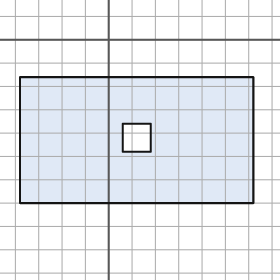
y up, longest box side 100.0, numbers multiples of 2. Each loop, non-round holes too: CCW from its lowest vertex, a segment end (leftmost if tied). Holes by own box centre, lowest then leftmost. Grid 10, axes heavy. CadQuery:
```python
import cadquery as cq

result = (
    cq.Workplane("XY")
    .moveTo(-38.0, -70.0)
    .lineTo(62.0, -70.0)
    .lineTo(62.0, -16.0)
    .lineTo(-38.0, -16.0)
    .close()
    .moveTo(6.0, -48.0)
    .lineTo(18.0, -48.0)
    .lineTo(18.0, -36.0)
    .lineTo(6.0, -36.0)
    .close()
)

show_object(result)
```